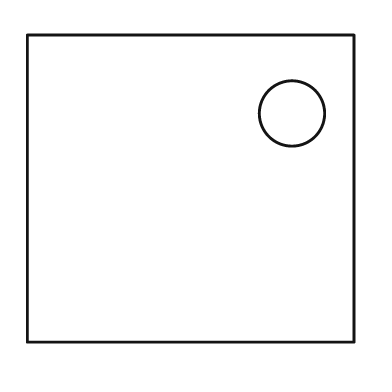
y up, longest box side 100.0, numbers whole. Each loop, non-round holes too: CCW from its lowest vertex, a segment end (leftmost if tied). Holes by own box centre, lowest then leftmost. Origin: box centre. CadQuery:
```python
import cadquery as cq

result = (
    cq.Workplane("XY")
    .moveTo(-50.0, -47.0)
    .lineTo(50.0, -47.0)
    .lineTo(50.0, 47.0)
    .lineTo(-50.0, 47.0)
    .close()
    .moveTo(31.0, 23.0)
    .circle(10.0)
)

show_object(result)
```